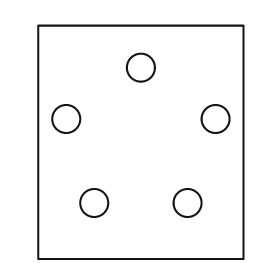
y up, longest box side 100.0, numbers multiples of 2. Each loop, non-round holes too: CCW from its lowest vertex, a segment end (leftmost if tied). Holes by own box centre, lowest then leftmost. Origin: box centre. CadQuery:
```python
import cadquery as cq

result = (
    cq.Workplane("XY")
    .moveTo(-44.0, -50.0)
    .lineTo(44.0, -50.0)
    .lineTo(44.0, 50.0)
    .lineTo(-44.0, 50.0)
    .close()
    .moveTo(-20.0, -26.0)
    .circle(6.0)
    .moveTo(20.0, -26.0)
    .circle(6.0)
    .moveTo(-32.0, 10.0)
    .circle(6.0)
    .moveTo(32.0, 10.0)
    .circle(6.0)
    .moveTo(0.0, 32.0)
    .circle(6.0)
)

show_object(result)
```